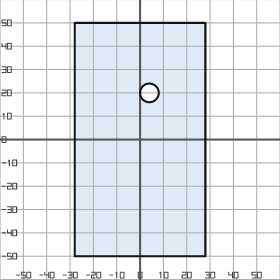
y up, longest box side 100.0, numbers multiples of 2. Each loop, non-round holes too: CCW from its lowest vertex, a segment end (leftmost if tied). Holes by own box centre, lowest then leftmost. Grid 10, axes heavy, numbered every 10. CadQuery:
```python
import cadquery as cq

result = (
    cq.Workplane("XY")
    .moveTo(-28.0, -50.0)
    .lineTo(28.0, -50.0)
    .lineTo(28.0, 50.0)
    .lineTo(-28.0, 50.0)
    .close()
    .moveTo(4.0, 20.0)
    .circle(4.0)
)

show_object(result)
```